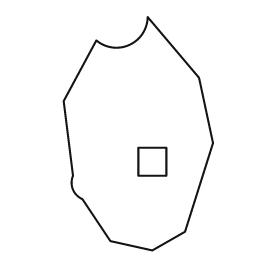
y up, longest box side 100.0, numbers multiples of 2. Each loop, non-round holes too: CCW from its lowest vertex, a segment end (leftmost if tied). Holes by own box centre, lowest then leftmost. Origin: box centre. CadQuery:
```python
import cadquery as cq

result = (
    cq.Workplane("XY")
    .moveTo(6.0, -50.0)
    .lineTo(20.0, -42.0)
    .lineTo(32.0, -4.0)
    .lineTo(26.0, 24.0)
    .lineTo(4.0, 50.0)
    .threePointArc((-4.0, 38.0), (-18.0, 40.0))
    .lineTo(-32.0, 14.0)
    .lineTo(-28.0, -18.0)
    .threePointArc((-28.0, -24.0), (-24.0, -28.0))
    .lineTo(-12.0, -46.0)
    .close()
    .moveTo(0.0, -18.0)
    .lineTo(12.0, -18.0)
    .lineTo(12.0, -6.0)
    .lineTo(0.0, -6.0)
    .close()
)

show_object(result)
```